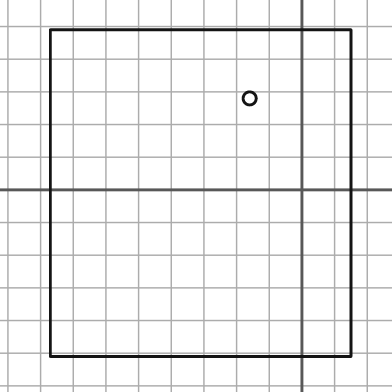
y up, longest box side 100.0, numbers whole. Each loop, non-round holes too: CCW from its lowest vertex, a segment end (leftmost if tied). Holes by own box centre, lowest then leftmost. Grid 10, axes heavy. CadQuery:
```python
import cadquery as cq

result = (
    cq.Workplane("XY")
    .moveTo(-77.0, -51.0)
    .lineTo(15.0, -51.0)
    .lineTo(15.0, 49.0)
    .lineTo(-77.0, 49.0)
    .close()
    .moveTo(-16.0, 28.0)
    .circle(2.0)
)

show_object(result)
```